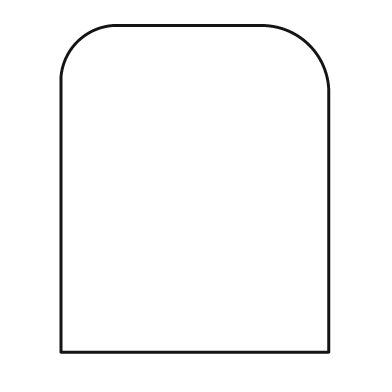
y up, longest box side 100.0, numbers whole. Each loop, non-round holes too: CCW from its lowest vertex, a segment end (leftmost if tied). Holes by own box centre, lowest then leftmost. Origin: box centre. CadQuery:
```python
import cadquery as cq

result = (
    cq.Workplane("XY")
    .moveTo(-41.0, -50.0)
    .lineTo(41.0, -50.0)
    .lineTo(41.0, 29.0)
    .threePointArc((35.0, 44.0), (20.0, 50.0))
    .lineTo(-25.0, 50.0)
    .threePointArc((-36.0, 45.0), (-41.0, 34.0))
    .close()
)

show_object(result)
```